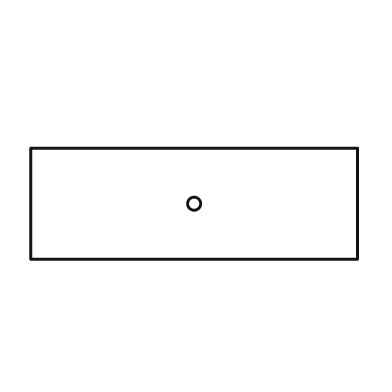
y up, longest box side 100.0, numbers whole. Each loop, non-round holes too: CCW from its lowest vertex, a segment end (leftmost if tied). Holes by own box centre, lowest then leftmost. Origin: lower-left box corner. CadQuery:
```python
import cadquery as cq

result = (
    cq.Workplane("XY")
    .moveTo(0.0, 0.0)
    .lineTo(100.0, 0.0)
    .lineTo(100.0, 34.0)
    .lineTo(0.0, 34.0)
    .close()
    .moveTo(50.0, 17.0)
    .circle(2.0)
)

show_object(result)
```